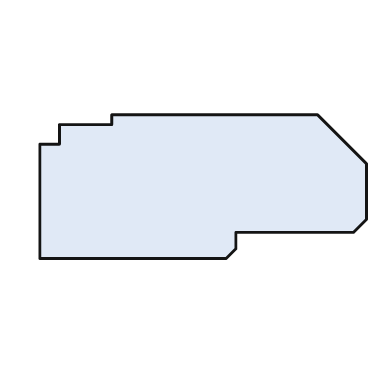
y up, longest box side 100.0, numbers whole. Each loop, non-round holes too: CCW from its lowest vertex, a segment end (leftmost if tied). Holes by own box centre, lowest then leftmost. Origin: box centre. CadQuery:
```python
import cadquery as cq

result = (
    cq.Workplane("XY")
    .moveTo(-50.0, -22.0)
    .lineTo(7.0, -22.0)
    .lineTo(10.0, -19.0)
    .lineTo(10.0, -14.0)
    .lineTo(46.0, -14.0)
    .lineTo(50.0, -10.0)
    .lineTo(50.0, 7.0)
    .lineTo(35.0, 22.0)
    .lineTo(-28.0, 22.0)
    .lineTo(-28.0, 19.0)
    .lineTo(-44.0, 19.0)
    .lineTo(-44.0, 13.0)
    .lineTo(-50.0, 13.0)
    .close()
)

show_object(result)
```